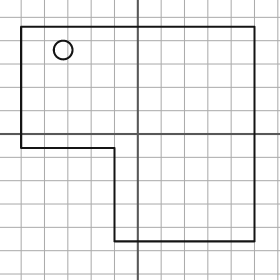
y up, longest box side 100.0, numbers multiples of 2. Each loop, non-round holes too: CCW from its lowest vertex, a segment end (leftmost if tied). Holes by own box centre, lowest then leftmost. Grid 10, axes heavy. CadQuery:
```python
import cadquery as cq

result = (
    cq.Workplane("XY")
    .moveTo(-10.0, -46.0)
    .lineTo(50.0, -46.0)
    .lineTo(50.0, 46.0)
    .lineTo(-50.0, 46.0)
    .lineTo(-50.0, -6.0)
    .lineTo(-10.0, -6.0)
    .close()
    .moveTo(-32.0, 36.0)
    .circle(4.0)
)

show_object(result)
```